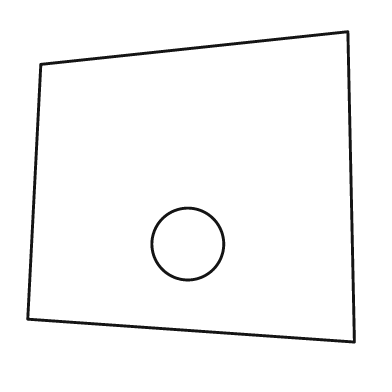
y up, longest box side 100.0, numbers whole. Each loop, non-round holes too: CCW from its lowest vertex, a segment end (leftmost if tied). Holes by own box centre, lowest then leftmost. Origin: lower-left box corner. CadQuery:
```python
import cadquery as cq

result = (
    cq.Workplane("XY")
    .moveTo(100.0, 0.0)
    .lineTo(98.0, 95.0)
    .lineTo(4.0, 85.0)
    .lineTo(0.0, 7.0)
    .close()
    .moveTo(49.0, 30.0)
    .circle(11.0)
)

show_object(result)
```